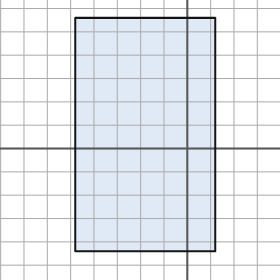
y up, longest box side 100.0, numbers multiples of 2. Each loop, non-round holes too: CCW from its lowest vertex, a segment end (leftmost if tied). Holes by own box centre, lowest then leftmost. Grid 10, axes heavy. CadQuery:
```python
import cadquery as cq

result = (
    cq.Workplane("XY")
    .moveTo(-48.0, -44.0)
    .lineTo(12.0, -44.0)
    .lineTo(12.0, 56.0)
    .lineTo(-48.0, 56.0)
    .close()
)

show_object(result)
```